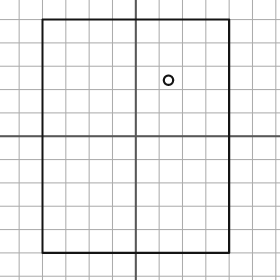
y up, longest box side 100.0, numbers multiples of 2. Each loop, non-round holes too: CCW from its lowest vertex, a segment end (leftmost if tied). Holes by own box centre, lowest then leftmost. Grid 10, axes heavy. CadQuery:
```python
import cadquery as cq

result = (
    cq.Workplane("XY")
    .moveTo(-40.0, -50.0)
    .lineTo(40.0, -50.0)
    .lineTo(40.0, 50.0)
    .lineTo(-40.0, 50.0)
    .close()
    .moveTo(14.0, 24.0)
    .circle(2.0)
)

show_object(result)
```